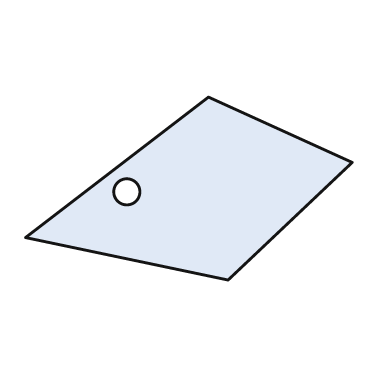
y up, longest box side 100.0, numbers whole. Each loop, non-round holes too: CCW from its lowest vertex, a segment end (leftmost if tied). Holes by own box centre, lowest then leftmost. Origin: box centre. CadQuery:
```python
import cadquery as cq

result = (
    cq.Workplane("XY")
    .moveTo(12.0, -28.0)
    .lineTo(50.0, 8.0)
    .lineTo(6.0, 28.0)
    .lineTo(-50.0, -15.0)
    .close()
    .moveTo(-19.0, -1.0)
    .circle(4.0)
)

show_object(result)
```